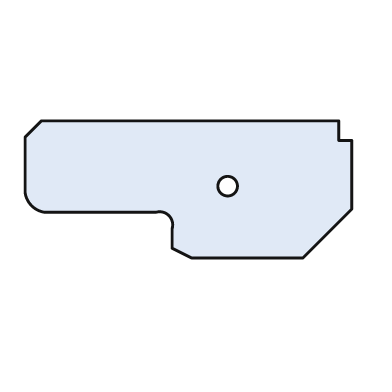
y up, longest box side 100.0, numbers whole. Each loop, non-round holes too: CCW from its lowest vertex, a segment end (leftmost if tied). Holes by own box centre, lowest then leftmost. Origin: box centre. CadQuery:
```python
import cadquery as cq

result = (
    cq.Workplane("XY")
    .moveTo(1.0, -21.0)
    .lineTo(35.0, -21.0)
    .lineTo(50.0, -6.0)
    .lineTo(50.0, 15.0)
    .lineTo(46.0, 15.0)
    .lineTo(46.0, 21.0)
    .lineTo(-45.0, 21.0)
    .lineTo(-50.0, 16.0)
    .lineTo(-50.0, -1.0)
    .threePointArc((-48.0, -5.0), (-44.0, -7.0))
    .lineTo(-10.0, -7.0)
    .threePointArc((-6.0, -8.0), (-5.0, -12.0))
    .lineTo(-5.0, -18.0)
    .close()
    .moveTo(12.0, 1.0)
    .circle(3.0)
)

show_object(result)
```